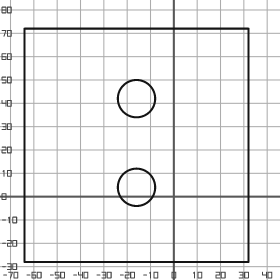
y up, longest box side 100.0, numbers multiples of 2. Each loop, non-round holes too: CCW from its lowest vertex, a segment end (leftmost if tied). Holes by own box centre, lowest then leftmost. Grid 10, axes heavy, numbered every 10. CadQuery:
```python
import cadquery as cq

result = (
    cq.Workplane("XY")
    .moveTo(-64.0, -28.0)
    .lineTo(32.0, -28.0)
    .lineTo(32.0, 72.0)
    .lineTo(-64.0, 72.0)
    .close()
    .moveTo(-16.0, 4.0)
    .circle(8.0)
    .moveTo(-16.0, 42.0)
    .circle(8.0)
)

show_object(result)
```